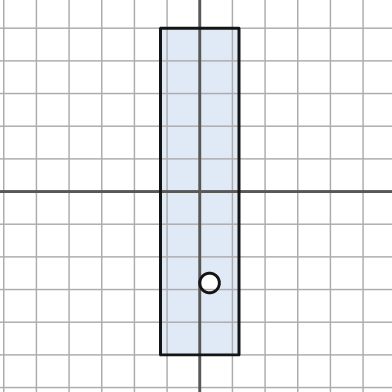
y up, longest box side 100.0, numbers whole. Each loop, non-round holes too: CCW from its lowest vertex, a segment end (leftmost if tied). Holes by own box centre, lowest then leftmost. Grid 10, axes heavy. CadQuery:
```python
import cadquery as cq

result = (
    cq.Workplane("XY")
    .moveTo(-12.0, -50.0)
    .lineTo(12.0, -50.0)
    .lineTo(12.0, 50.0)
    .lineTo(-12.0, 50.0)
    .close()
    .moveTo(3.0, -28.0)
    .circle(3.0)
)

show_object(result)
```